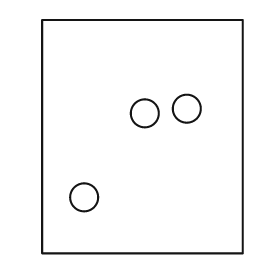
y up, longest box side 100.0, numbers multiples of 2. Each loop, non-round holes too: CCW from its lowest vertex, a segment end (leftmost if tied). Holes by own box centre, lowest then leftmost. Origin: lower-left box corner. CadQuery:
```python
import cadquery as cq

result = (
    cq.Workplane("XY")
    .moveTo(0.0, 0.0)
    .lineTo(86.0, 0.0)
    .lineTo(86.0, 100.0)
    .lineTo(0.0, 100.0)
    .close()
    .moveTo(18.0, 24.0)
    .circle(6.0)
    .moveTo(44.0, 60.0)
    .circle(6.0)
    .moveTo(62.0, 62.0)
    .circle(6.0)
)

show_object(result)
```